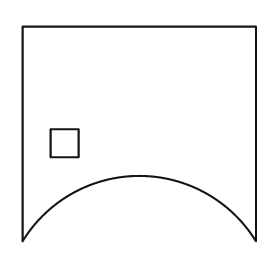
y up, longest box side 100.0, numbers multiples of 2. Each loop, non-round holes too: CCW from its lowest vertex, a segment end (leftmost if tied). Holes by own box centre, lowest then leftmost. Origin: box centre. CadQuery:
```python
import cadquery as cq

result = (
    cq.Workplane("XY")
    .moveTo(-50.0, -46.0)
    .threePointArc((0.0, -18.0), (50.0, -46.0))
    .lineTo(50.0, 46.0)
    .lineTo(-50.0, 46.0)
    .close()
    .moveTo(-38.0, -10.0)
    .lineTo(-26.0, -10.0)
    .lineTo(-26.0, 2.0)
    .lineTo(-38.0, 2.0)
    .close()
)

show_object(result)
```